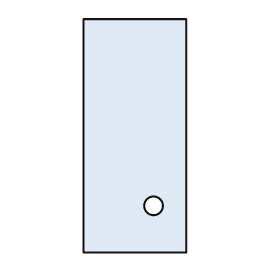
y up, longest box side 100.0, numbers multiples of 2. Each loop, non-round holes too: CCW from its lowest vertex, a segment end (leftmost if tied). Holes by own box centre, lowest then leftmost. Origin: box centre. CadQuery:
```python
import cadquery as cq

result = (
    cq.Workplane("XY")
    .moveTo(-22.0, -50.0)
    .lineTo(22.0, -50.0)
    .lineTo(22.0, 50.0)
    .lineTo(-22.0, 50.0)
    .close()
    .moveTo(8.0, -30.0)
    .circle(4.0)
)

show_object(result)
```